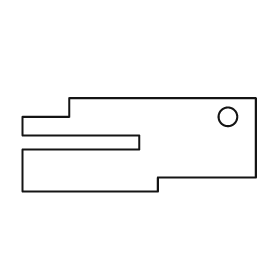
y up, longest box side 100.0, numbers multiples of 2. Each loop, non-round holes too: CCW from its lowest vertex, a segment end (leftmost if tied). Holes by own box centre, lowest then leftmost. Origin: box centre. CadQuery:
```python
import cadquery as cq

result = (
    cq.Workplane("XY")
    .moveTo(-50.0, -20.0)
    .lineTo(8.0, -20.0)
    .lineTo(8.0, -14.0)
    .lineTo(50.0, -14.0)
    .lineTo(50.0, 20.0)
    .lineTo(-30.0, 20.0)
    .lineTo(-30.0, 12.0)
    .lineTo(-50.0, 12.0)
    .lineTo(-50.0, 4.0)
    .lineTo(0.0, 4.0)
    .lineTo(0.0, -2.0)
    .lineTo(-50.0, -2.0)
    .close()
    .moveTo(38.0, 12.0)
    .circle(4.0)
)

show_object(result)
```